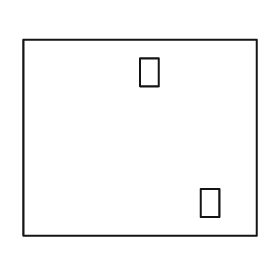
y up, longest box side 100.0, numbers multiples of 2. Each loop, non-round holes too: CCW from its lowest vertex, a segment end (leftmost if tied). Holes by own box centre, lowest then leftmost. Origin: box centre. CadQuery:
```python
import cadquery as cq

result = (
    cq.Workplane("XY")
    .moveTo(-50.0, -42.0)
    .lineTo(50.0, -42.0)
    .lineTo(50.0, 42.0)
    .lineTo(-50.0, 42.0)
    .close()
    .moveTo(26.0, -34.0)
    .lineTo(34.0, -34.0)
    .lineTo(34.0, -22.0)
    .lineTo(26.0, -22.0)
    .close()
    .moveTo(0.0, 22.0)
    .lineTo(8.0, 22.0)
    .lineTo(8.0, 34.0)
    .lineTo(0.0, 34.0)
    .close()
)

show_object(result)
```